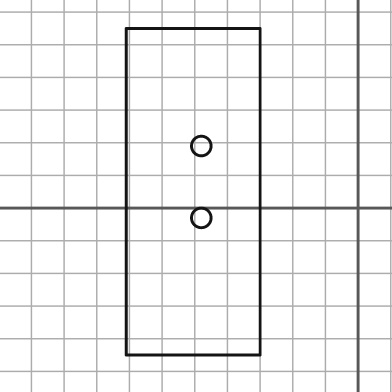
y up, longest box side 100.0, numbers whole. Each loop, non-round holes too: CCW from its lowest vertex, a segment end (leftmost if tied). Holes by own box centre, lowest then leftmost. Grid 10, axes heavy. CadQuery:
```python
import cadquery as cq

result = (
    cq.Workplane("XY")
    .moveTo(-71.0, -45.0)
    .lineTo(-30.0, -45.0)
    .lineTo(-30.0, 55.0)
    .lineTo(-71.0, 55.0)
    .close()
    .moveTo(-48.0, -3.0)
    .circle(3.0)
    .moveTo(-48.0, 19.0)
    .circle(3.0)
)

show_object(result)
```